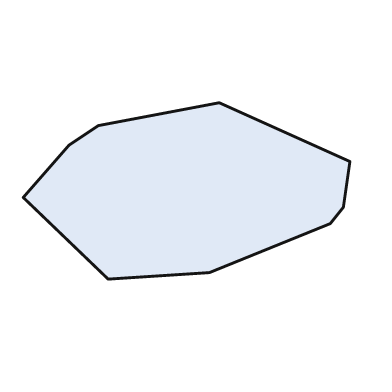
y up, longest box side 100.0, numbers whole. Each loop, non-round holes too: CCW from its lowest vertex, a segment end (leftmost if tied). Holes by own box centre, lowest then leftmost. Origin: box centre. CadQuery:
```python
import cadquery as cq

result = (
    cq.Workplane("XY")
    .moveTo(-24.0, -27.0)
    .lineTo(7.0, -25.0)
    .lineTo(44.0, -10.0)
    .lineTo(48.0, -5.0)
    .lineTo(50.0, 9.0)
    .lineTo(10.0, 27.0)
    .lineTo(-27.0, 20.0)
    .lineTo(-36.0, 14.0)
    .lineTo(-50.0, -2.0)
    .close()
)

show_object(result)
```